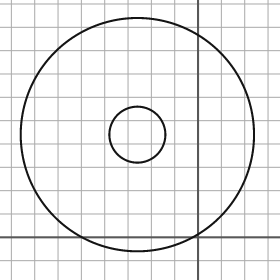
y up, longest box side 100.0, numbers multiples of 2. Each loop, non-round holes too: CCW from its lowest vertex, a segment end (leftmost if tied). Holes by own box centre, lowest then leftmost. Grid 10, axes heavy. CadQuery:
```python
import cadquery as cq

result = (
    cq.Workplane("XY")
    .moveTo(-26.0, 44.0)
    .circle(50.0)
    .moveTo(-26.0, 44.0)
    .circle(12.0)
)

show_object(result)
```